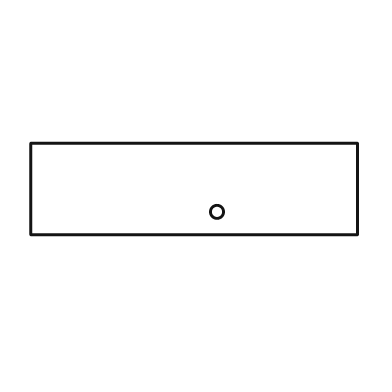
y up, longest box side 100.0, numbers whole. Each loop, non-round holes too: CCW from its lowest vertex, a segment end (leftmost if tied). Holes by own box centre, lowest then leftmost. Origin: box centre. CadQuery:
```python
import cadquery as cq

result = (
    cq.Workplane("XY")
    .moveTo(-50.0, -14.0)
    .lineTo(50.0, -14.0)
    .lineTo(50.0, 14.0)
    .lineTo(-50.0, 14.0)
    .close()
    .moveTo(7.0, -7.0)
    .circle(2.0)
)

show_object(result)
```